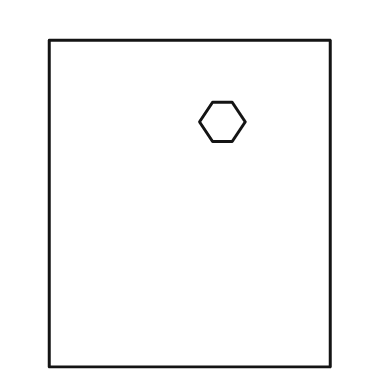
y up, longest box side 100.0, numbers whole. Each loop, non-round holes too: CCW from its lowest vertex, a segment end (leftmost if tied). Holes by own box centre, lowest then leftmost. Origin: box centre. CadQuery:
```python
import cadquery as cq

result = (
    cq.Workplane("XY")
    .moveTo(-43.0, -50.0)
    .lineTo(43.0, -50.0)
    .lineTo(43.0, 50.0)
    .lineTo(-43.0, 50.0)
    .close()
    .moveTo(7.0, 19.0)
    .lineTo(13.0, 19.0)
    .lineTo(17.0, 25.0)
    .lineTo(13.0, 31.0)
    .lineTo(7.0, 31.0)
    .lineTo(3.0, 25.0)
    .close()
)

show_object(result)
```